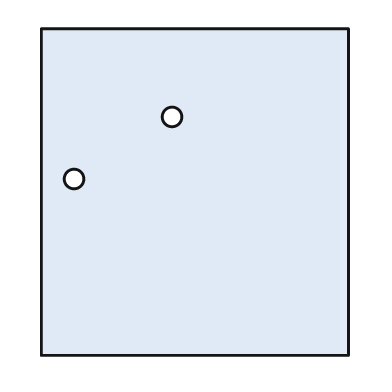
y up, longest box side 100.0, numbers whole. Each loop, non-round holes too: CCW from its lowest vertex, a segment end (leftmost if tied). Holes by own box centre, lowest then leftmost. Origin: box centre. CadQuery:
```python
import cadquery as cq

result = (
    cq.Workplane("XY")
    .moveTo(-47.0, -50.0)
    .lineTo(47.0, -50.0)
    .lineTo(47.0, 50.0)
    .lineTo(-47.0, 50.0)
    .close()
    .moveTo(-37.0, 4.0)
    .circle(3.0)
    .moveTo(-7.0, 23.0)
    .circle(3.0)
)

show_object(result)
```